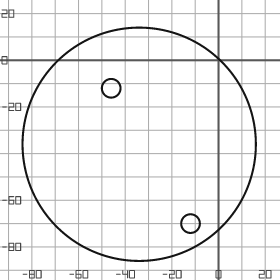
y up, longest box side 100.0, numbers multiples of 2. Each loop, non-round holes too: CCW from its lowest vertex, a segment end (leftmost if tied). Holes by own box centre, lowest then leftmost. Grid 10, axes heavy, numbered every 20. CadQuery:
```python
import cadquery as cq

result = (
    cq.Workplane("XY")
    .moveTo(-34.0, -36.0)
    .circle(50.0)
    .moveTo(-12.0, -70.0)
    .circle(4.0)
    .moveTo(-46.0, -12.0)
    .circle(4.0)
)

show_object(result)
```